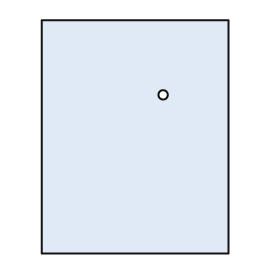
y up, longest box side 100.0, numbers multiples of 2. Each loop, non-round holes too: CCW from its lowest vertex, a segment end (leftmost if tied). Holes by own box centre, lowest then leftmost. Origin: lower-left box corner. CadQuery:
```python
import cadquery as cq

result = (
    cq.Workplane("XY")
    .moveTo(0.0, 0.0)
    .lineTo(80.0, 0.0)
    .lineTo(80.0, 100.0)
    .lineTo(0.0, 100.0)
    .close()
    .moveTo(52.0, 68.0)
    .circle(2.0)
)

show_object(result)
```